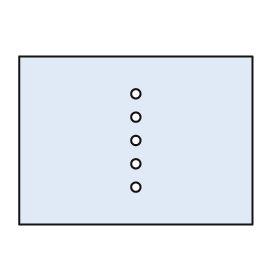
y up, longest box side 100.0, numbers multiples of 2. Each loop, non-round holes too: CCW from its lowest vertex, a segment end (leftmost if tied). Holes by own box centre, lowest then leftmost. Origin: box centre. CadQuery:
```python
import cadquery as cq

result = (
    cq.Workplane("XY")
    .moveTo(-50.0, -36.0)
    .lineTo(50.0, -36.0)
    .lineTo(50.0, 36.0)
    .lineTo(-50.0, 36.0)
    .close()
    .moveTo(0.0, -20.0)
    .circle(2.0)
    .moveTo(0.0, -10.0)
    .circle(2.0)
    .moveTo(0.0, 0.0)
    .circle(2.0)
    .moveTo(0.0, 10.0)
    .circle(2.0)
    .moveTo(0.0, 20.0)
    .circle(2.0)
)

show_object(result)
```